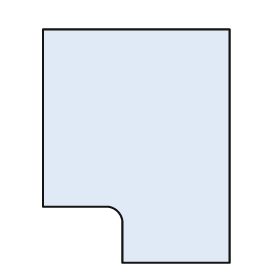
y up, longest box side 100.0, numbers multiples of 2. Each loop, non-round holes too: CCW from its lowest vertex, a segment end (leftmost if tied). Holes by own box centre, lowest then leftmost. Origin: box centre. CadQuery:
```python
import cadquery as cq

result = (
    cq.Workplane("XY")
    .moveTo(-6.0, -50.0)
    .lineTo(40.0, -50.0)
    .lineTo(40.0, 50.0)
    .lineTo(-40.0, 50.0)
    .lineTo(-40.0, -26.0)
    .lineTo(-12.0, -26.0)
    .threePointArc((-8.0, -28.0), (-6.0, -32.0))
    .close()
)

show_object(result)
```